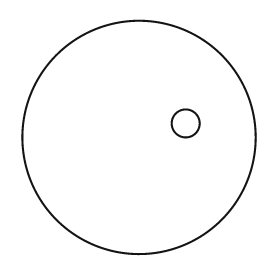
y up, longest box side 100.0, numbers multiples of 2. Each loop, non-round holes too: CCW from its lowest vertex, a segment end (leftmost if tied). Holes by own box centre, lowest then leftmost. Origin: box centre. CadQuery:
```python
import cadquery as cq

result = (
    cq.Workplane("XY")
    .moveTo(0.0, 0.0)
    .circle(50.0)
    .moveTo(20.0, 6.0)
    .circle(6.0)
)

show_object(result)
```